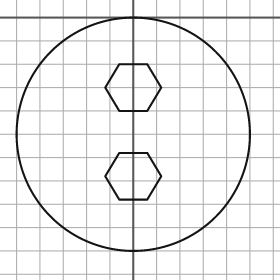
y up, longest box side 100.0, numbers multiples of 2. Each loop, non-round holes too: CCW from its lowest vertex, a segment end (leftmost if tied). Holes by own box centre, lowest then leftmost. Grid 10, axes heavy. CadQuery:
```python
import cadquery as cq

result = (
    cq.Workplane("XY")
    .moveTo(0.0, -50.0)
    .circle(50.0)
    .moveTo(-6.0, -78.0)
    .lineTo(6.0, -78.0)
    .lineTo(12.0, -68.0)
    .lineTo(6.0, -58.0)
    .lineTo(-6.0, -58.0)
    .lineTo(-12.0, -68.0)
    .close()
    .moveTo(-6.0, -40.0)
    .lineTo(6.0, -40.0)
    .lineTo(12.0, -30.0)
    .lineTo(6.0, -20.0)
    .lineTo(-6.0, -20.0)
    .lineTo(-12.0, -30.0)
    .close()
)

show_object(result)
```